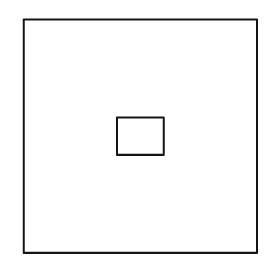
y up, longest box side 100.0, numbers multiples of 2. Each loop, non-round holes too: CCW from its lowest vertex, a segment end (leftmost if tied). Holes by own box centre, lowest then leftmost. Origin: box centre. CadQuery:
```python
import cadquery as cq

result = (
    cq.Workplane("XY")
    .moveTo(-50.0, -50.0)
    .lineTo(50.0, -50.0)
    .lineTo(50.0, 50.0)
    .lineTo(-50.0, 50.0)
    .close()
    .moveTo(-10.0, -8.0)
    .lineTo(10.0, -8.0)
    .lineTo(10.0, 8.0)
    .lineTo(-10.0, 8.0)
    .close()
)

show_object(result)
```